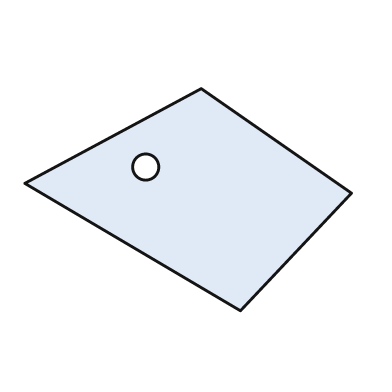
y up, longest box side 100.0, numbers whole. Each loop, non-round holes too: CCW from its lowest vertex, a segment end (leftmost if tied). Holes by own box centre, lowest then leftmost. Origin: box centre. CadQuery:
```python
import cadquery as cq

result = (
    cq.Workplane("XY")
    .moveTo(16.0, -34.0)
    .lineTo(50.0, 2.0)
    .lineTo(4.0, 34.0)
    .lineTo(-50.0, 5.0)
    .close()
    .moveTo(-13.0, 10.0)
    .circle(4.0)
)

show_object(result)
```